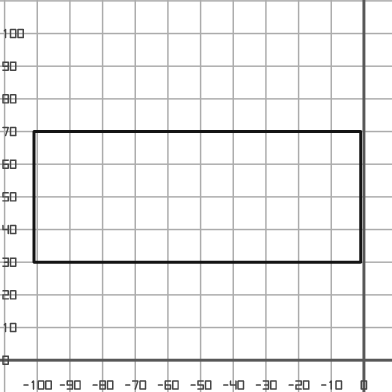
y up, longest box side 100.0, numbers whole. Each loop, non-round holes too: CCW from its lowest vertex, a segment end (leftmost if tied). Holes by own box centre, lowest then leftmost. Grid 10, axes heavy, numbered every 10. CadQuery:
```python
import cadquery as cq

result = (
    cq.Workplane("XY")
    .moveTo(-101.0, 30.0)
    .lineTo(-1.0, 30.0)
    .lineTo(-1.0, 70.0)
    .lineTo(-101.0, 70.0)
    .close()
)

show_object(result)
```